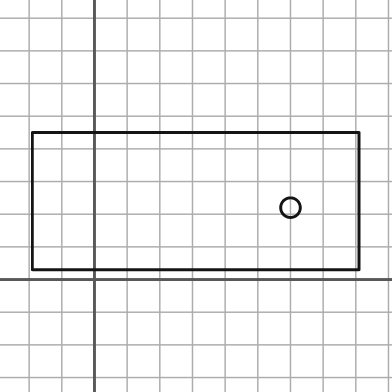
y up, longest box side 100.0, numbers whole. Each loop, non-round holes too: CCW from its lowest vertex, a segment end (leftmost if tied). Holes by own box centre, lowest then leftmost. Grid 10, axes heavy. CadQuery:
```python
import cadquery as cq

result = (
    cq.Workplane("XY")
    .moveTo(-19.0, 3.0)
    .lineTo(81.0, 3.0)
    .lineTo(81.0, 45.0)
    .lineTo(-19.0, 45.0)
    .close()
    .moveTo(60.0, 22.0)
    .circle(3.0)
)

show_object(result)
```